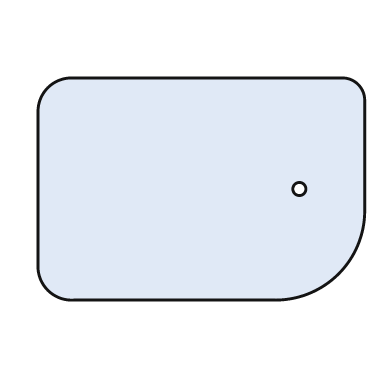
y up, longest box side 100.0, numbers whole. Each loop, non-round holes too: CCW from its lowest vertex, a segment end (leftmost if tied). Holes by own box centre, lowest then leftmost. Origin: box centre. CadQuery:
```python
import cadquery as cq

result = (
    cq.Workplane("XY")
    .moveTo(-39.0, -34.0)
    .lineTo(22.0, -34.0)
    .threePointArc((42.0, -26.0), (50.0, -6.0))
    .lineTo(50.0, 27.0)
    .threePointArc((48.0, 32.0), (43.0, 34.0))
    .lineTo(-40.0, 34.0)
    .threePointArc((-47.0, 31.0), (-50.0, 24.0))
    .lineTo(-50.0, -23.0)
    .threePointArc((-47.0, -31.0), (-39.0, -34.0))
    .close()
    .moveTo(30.0, 0.0)
    .circle(2.0)
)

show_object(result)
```